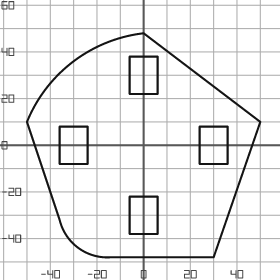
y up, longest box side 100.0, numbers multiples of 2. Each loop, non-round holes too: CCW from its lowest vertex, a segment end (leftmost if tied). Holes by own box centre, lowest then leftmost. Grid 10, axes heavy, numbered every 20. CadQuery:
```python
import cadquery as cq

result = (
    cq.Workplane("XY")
    .moveTo(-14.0, -48.0)
    .lineTo(30.0, -48.0)
    .lineTo(50.0, 10.0)
    .lineTo(0.0, 48.0)
    .threePointArc((-30.0, 36.0), (-50.0, 10.0))
    .lineTo(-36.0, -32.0)
    .threePointArc((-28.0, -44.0), (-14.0, -48.0))
    .close()
    .moveTo(-6.0, -38.0)
    .lineTo(6.0, -38.0)
    .lineTo(6.0, -22.0)
    .lineTo(-6.0, -22.0)
    .close()
    .moveTo(-36.0, -8.0)
    .lineTo(-24.0, -8.0)
    .lineTo(-24.0, 8.0)
    .lineTo(-36.0, 8.0)
    .close()
    .moveTo(24.0, -8.0)
    .lineTo(36.0, -8.0)
    .lineTo(36.0, 8.0)
    .lineTo(24.0, 8.0)
    .close()
    .moveTo(-6.0, 22.0)
    .lineTo(6.0, 22.0)
    .lineTo(6.0, 38.0)
    .lineTo(-6.0, 38.0)
    .close()
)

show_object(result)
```